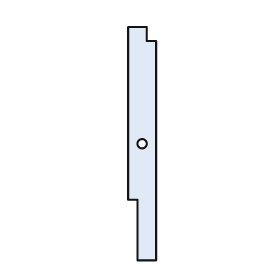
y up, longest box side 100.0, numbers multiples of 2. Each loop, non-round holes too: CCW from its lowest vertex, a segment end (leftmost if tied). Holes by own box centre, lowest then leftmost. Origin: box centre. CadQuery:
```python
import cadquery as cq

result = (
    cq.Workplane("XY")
    .moveTo(-2.0, -50.0)
    .lineTo(6.0, -50.0)
    .lineTo(6.0, 44.0)
    .lineTo(2.0, 44.0)
    .lineTo(2.0, 50.0)
    .lineTo(-6.0, 50.0)
    .lineTo(-6.0, -24.0)
    .lineTo(-2.0, -24.0)
    .close()
    .moveTo(0.0, 0.0)
    .circle(2.0)
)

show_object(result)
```